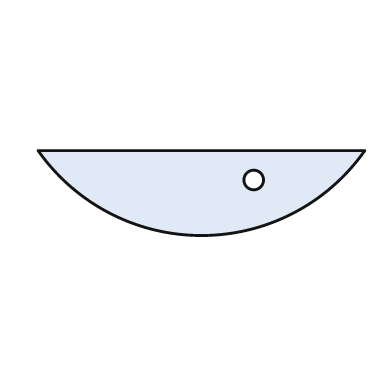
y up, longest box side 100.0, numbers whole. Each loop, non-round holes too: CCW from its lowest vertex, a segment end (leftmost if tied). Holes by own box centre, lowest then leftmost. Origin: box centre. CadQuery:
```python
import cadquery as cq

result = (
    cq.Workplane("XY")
    .moveTo(-50.0, 13.0)
    .threePointArc((0.0, -13.0), (50.0, 13.0))
    .close()
    .moveTo(16.0, 4.0)
    .circle(3.0)
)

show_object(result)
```